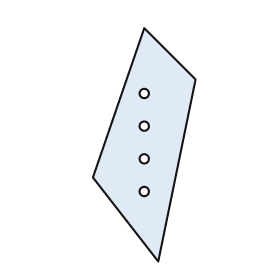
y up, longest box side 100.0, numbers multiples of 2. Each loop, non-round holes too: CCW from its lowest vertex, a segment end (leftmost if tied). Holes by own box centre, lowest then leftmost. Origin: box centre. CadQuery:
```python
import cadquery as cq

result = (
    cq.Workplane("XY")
    .moveTo(6.0, -50.0)
    .lineTo(22.0, 28.0)
    .lineTo(0.0, 50.0)
    .lineTo(-22.0, -14.0)
    .close()
    .moveTo(0.0, -20.0)
    .circle(2.0)
    .moveTo(0.0, -6.0)
    .circle(2.0)
    .moveTo(0.0, 8.0)
    .circle(2.0)
    .moveTo(0.0, 22.0)
    .circle(2.0)
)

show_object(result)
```